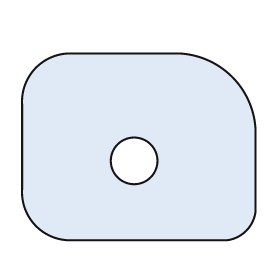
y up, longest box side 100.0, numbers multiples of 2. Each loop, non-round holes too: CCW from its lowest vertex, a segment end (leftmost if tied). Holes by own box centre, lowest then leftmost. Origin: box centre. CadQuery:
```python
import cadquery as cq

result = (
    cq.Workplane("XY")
    .moveTo(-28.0, -40.0)
    .lineTo(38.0, -40.0)
    .threePointArc((46.0, -36.0), (50.0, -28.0))
    .lineTo(50.0, 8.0)
    .threePointArc((40.0, 30.0), (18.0, 40.0))
    .lineTo(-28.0, 40.0)
    .threePointArc((-44.0, 34.0), (-50.0, 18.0))
    .lineTo(-50.0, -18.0)
    .threePointArc((-44.0, -34.0), (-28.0, -40.0))
    .close()
    .moveTo(-2.0, -6.0)
    .circle(10.0)
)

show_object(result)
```